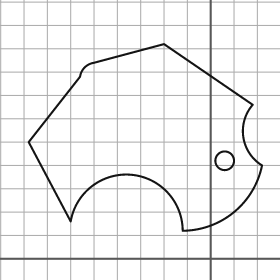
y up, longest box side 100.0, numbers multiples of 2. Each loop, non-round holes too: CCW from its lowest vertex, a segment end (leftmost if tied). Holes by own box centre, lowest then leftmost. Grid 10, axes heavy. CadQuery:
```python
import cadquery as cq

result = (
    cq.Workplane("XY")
    .moveTo(-12.0, 12.0)
    .threePointArc((10.0, 20.0), (22.0, 40.0))
    .threePointArc((14.0, 52.0), (18.0, 66.0))
    .lineTo(-20.0, 92.0)
    .lineTo(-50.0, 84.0)
    .threePointArc((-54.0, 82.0), (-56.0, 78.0))
    .lineTo(-78.0, 50.0)
    .lineTo(-60.0, 16.0)
    .threePointArc((-34.0, 36.0), (-12.0, 12.0))
    .close()
    .moveTo(6.0, 42.0)
    .circle(4.0)
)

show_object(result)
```